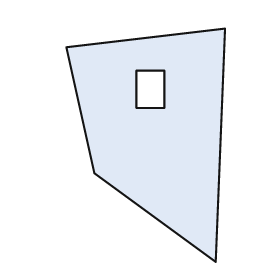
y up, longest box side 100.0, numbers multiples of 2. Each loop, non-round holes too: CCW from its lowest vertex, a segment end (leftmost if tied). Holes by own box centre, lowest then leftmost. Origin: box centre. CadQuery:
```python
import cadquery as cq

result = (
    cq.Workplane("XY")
    .moveTo(30.0, -50.0)
    .lineTo(34.0, 50.0)
    .lineTo(-34.0, 42.0)
    .lineTo(-22.0, -12.0)
    .close()
    .moveTo(-4.0, 16.0)
    .lineTo(8.0, 16.0)
    .lineTo(8.0, 32.0)
    .lineTo(-4.0, 32.0)
    .close()
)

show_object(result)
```